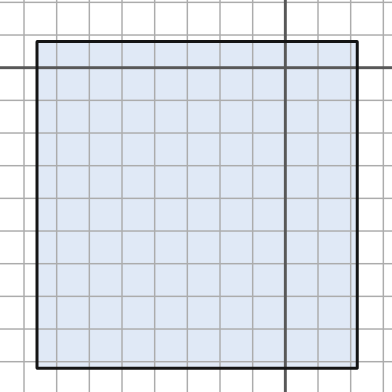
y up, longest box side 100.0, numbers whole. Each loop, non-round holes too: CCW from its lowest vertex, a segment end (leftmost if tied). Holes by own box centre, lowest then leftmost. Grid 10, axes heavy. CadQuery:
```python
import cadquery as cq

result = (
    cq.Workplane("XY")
    .moveTo(-76.0, -92.0)
    .lineTo(22.0, -92.0)
    .lineTo(22.0, 8.0)
    .lineTo(-76.0, 8.0)
    .close()
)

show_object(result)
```